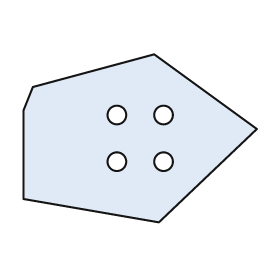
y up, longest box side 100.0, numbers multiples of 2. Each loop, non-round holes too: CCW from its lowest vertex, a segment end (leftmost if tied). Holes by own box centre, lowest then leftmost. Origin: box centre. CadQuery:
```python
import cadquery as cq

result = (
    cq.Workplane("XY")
    .moveTo(8.0, -36.0)
    .lineTo(50.0, 4.0)
    .lineTo(6.0, 36.0)
    .lineTo(-46.0, 22.0)
    .lineTo(-50.0, 12.0)
    .lineTo(-50.0, -26.0)
    .close()
    .moveTo(-10.0, -10.0)
    .circle(4.0)
    .moveTo(10.0, -10.0)
    .circle(4.0)
    .moveTo(-10.0, 10.0)
    .circle(4.0)
    .moveTo(10.0, 10.0)
    .circle(4.0)
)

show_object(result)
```